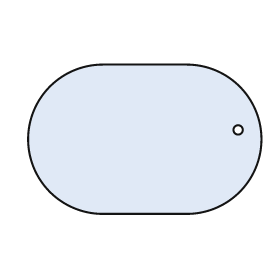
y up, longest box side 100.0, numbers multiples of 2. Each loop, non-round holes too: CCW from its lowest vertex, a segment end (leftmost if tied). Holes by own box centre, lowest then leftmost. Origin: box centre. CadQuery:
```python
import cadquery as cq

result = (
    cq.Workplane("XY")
    .moveTo(-18.0, -32.0)
    .lineTo(18.0, -32.0)
    .threePointArc((50.0, 0.0), (18.0, 32.0))
    .lineTo(-18.0, 32.0)
    .threePointArc((-50.0, 0.0), (-18.0, -32.0))
    .close()
    .moveTo(40.0, 4.0)
    .circle(2.0)
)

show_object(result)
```